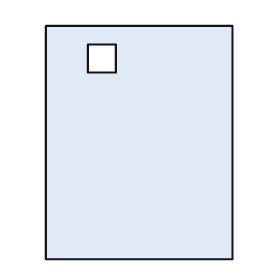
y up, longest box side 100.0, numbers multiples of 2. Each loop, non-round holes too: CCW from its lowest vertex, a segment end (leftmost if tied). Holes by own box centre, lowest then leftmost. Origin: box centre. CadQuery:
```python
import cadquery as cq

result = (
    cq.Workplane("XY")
    .moveTo(-40.0, -50.0)
    .lineTo(40.0, -50.0)
    .lineTo(40.0, 50.0)
    .lineTo(-40.0, 50.0)
    .close()
    .moveTo(-22.0, 30.0)
    .lineTo(-10.0, 30.0)
    .lineTo(-10.0, 42.0)
    .lineTo(-22.0, 42.0)
    .close()
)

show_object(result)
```